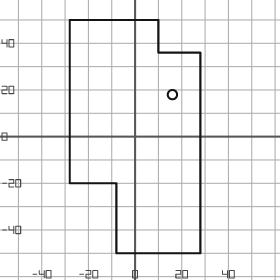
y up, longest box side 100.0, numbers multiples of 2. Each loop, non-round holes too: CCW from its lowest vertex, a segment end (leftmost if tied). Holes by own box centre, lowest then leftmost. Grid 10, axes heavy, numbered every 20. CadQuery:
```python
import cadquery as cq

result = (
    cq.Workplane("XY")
    .moveTo(-8.0, -50.0)
    .lineTo(28.0, -50.0)
    .lineTo(28.0, 36.0)
    .lineTo(10.0, 36.0)
    .lineTo(10.0, 50.0)
    .lineTo(-28.0, 50.0)
    .lineTo(-28.0, -20.0)
    .lineTo(-8.0, -20.0)
    .close()
    .moveTo(16.0, 18.0)
    .circle(2.0)
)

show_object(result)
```